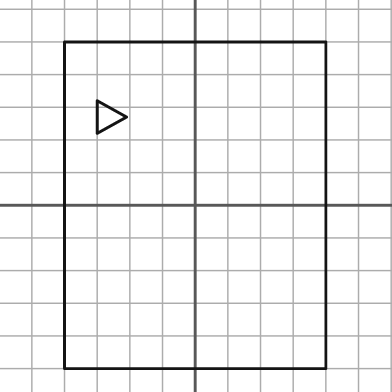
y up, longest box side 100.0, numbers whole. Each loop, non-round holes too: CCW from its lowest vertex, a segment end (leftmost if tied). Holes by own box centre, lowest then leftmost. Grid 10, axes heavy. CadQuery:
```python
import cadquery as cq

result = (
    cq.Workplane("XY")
    .moveTo(-40.0, -50.0)
    .lineTo(40.0, -50.0)
    .lineTo(40.0, 50.0)
    .lineTo(-40.0, 50.0)
    .close()
    .moveTo(-30.0, 22.0)
    .lineTo(-21.0, 27.0)
    .lineTo(-30.0, 32.0)
    .close()
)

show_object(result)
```